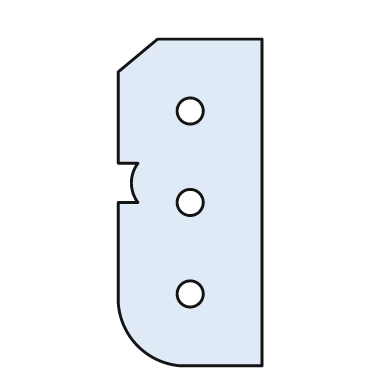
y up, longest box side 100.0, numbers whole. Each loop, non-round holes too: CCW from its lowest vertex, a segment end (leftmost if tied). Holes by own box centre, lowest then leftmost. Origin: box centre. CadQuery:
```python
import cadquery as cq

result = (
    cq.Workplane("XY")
    .moveTo(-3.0, -50.0)
    .lineTo(22.0, -50.0)
    .lineTo(22.0, 50.0)
    .lineTo(-10.0, 50.0)
    .lineTo(-22.0, 40.0)
    .lineTo(-22.0, 12.0)
    .lineTo(-16.0, 12.0)
    .threePointArc((-18.0, 6.0), (-16.0, 0.0))
    .lineTo(-22.0, 0.0)
    .lineTo(-22.0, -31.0)
    .threePointArc((-16.0, -44.0), (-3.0, -50.0))
    .close()
    .moveTo(0.0, -28.0)
    .circle(4.0)
    .moveTo(0.0, 0.0)
    .circle(4.0)
    .moveTo(0.0, 28.0)
    .circle(4.0)
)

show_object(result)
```